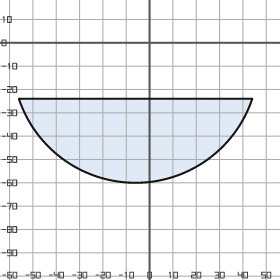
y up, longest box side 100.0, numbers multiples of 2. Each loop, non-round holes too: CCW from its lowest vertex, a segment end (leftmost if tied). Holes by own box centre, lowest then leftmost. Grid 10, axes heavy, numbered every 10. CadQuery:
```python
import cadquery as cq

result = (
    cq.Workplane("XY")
    .moveTo(-56.0, -24.0)
    .threePointArc((-6.0, -60.0), (44.0, -24.0))
    .close()
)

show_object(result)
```